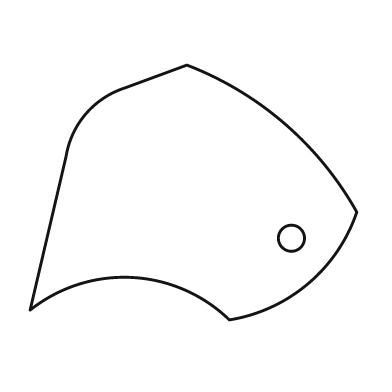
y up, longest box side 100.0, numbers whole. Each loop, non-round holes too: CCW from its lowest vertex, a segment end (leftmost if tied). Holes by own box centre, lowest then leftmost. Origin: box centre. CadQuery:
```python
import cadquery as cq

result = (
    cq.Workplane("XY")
    .moveTo(11.0, -39.0)
    .threePointArc((35.0, -28.0), (50.0, -6.0))
    .threePointArc((28.0, 21.0), (-2.0, 39.0))
    .lineTo(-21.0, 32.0)
    .threePointArc((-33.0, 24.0), (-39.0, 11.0))
    .lineTo(-50.0, -36.0)
    .threePointArc((-19.0, -26.0), (11.0, -39.0))
    .close()
    .moveTo(30.0, -14.0)
    .circle(4.0)
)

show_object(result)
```